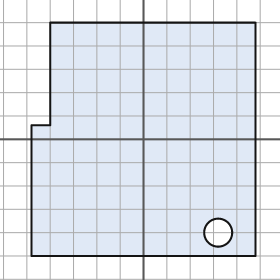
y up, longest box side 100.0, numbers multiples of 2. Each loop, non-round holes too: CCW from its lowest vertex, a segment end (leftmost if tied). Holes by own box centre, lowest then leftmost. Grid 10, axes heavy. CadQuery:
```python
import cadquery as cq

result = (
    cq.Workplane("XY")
    .moveTo(-48.0, -50.0)
    .lineTo(48.0, -50.0)
    .lineTo(48.0, 50.0)
    .lineTo(-40.0, 50.0)
    .lineTo(-40.0, 6.0)
    .lineTo(-48.0, 6.0)
    .close()
    .moveTo(32.0, -40.0)
    .circle(6.0)
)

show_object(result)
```